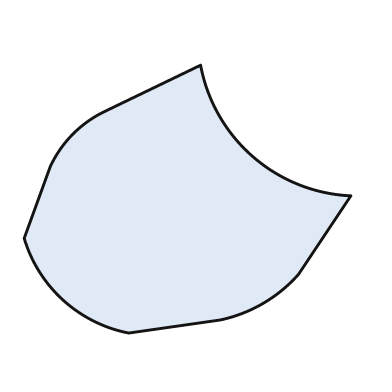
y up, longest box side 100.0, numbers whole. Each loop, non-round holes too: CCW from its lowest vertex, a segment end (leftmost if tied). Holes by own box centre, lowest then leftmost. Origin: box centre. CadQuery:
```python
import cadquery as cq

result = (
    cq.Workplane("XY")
    .moveTo(-18.0, -41.0)
    .lineTo(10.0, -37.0)
    .threePointArc((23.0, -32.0), (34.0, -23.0))
    .lineTo(50.0, 1.0)
    .threePointArc((20.0, 13.0), (4.0, 41.0))
    .lineTo(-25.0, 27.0)
    .threePointArc((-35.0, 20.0), (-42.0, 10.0))
    .lineTo(-50.0, -12.0)
    .threePointArc((-38.0, -31.0), (-18.0, -41.0))
    .close()
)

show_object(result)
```